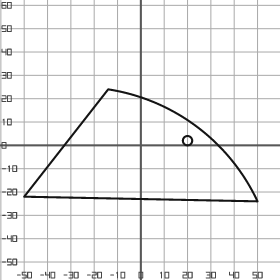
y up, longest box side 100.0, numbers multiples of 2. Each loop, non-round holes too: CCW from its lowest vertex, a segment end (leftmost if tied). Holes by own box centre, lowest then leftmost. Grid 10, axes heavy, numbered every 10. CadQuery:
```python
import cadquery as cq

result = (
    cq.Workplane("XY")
    .moveTo(50.0, -24.0)
    .threePointArc((24.0, 8.0), (-14.0, 24.0))
    .lineTo(-50.0, -22.0)
    .close()
    .moveTo(20.0, 2.0)
    .circle(2.0)
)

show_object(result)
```